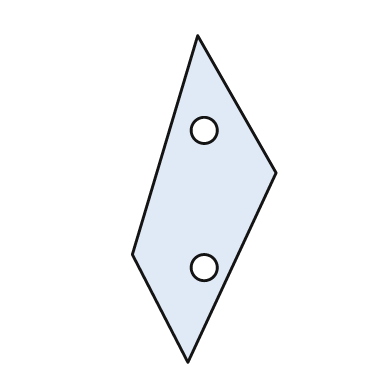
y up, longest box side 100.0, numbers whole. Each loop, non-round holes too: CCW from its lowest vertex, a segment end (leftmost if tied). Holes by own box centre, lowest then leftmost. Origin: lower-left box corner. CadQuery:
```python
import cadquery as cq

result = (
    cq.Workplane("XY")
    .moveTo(17.0, 0.0)
    .lineTo(44.0, 58.0)
    .lineTo(20.0, 100.0)
    .lineTo(0.0, 33.0)
    .close()
    .moveTo(22.0, 29.0)
    .circle(4.0)
    .moveTo(22.0, 71.0)
    .circle(4.0)
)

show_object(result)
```